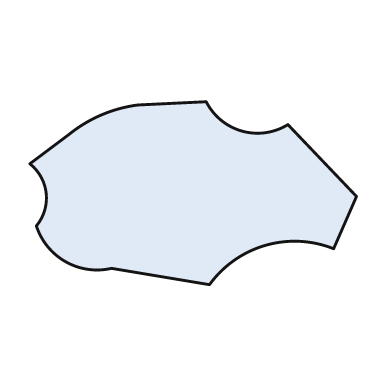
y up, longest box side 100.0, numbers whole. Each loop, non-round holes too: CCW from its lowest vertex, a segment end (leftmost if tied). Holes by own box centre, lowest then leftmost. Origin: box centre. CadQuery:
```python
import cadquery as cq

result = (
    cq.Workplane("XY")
    .moveTo(5.0, -28.0)
    .threePointArc((22.0, -16.0), (43.0, -17.0))
    .lineTo(50.0, -1.0)
    .lineTo(29.0, 21.0)
    .threePointArc((15.0, 19.0), (4.0, 28.0))
    .lineTo(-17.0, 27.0)
    .threePointArc((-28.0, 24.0), (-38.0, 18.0))
    .lineTo(-50.0, 9.0)
    .threePointArc((-45.0, 0.0), (-48.0, -10.0))
    .threePointArc((-39.0, -21.0), (-25.0, -23.0))
    .close()
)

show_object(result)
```